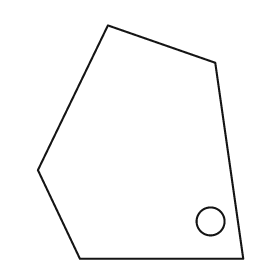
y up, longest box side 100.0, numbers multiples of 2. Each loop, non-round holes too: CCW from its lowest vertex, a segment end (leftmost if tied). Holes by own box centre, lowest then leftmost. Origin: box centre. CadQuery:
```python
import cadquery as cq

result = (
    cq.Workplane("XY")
    .moveTo(-26.0, -50.0)
    .lineTo(44.0, -50.0)
    .lineTo(32.0, 34.0)
    .lineTo(-14.0, 50.0)
    .lineTo(-44.0, -12.0)
    .close()
    .moveTo(30.0, -34.0)
    .circle(6.0)
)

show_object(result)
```